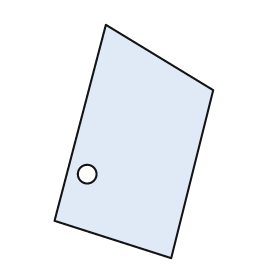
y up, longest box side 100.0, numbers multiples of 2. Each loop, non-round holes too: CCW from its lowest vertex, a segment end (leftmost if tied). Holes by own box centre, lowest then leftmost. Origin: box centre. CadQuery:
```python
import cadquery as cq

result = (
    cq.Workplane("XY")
    .moveTo(16.0, -50.0)
    .lineTo(34.0, 22.0)
    .lineTo(-12.0, 50.0)
    .lineTo(-34.0, -34.0)
    .close()
    .moveTo(-20.0, -14.0)
    .circle(4.0)
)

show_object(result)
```